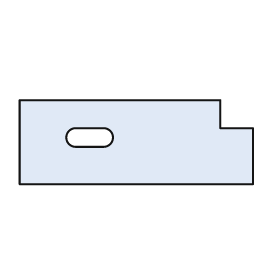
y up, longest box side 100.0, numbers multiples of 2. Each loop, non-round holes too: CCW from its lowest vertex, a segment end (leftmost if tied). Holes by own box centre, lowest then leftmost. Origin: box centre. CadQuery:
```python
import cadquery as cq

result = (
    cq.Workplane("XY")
    .moveTo(-50.0, -18.0)
    .lineTo(50.0, -18.0)
    .lineTo(50.0, 6.0)
    .lineTo(36.0, 6.0)
    .lineTo(36.0, 18.0)
    .lineTo(-50.0, 18.0)
    .close()
    .moveTo(-26.0, -2.0)
    .lineTo(-14.0, -2.0)
    .threePointArc((-10.0, 2.0), (-14.0, 6.0))
    .lineTo(-26.0, 6.0)
    .threePointArc((-30.0, 2.0), (-26.0, -2.0))
    .close()
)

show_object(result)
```